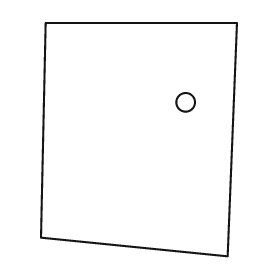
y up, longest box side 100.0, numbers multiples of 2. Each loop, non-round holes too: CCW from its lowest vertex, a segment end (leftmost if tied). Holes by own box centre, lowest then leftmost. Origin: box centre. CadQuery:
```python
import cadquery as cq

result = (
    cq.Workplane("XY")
    .moveTo(38.0, -50.0)
    .lineTo(42.0, 50.0)
    .lineTo(-40.0, 50.0)
    .lineTo(-42.0, -42.0)
    .close()
    .moveTo(20.0, 16.0)
    .circle(4.0)
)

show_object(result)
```